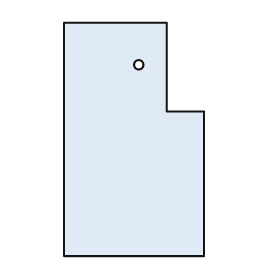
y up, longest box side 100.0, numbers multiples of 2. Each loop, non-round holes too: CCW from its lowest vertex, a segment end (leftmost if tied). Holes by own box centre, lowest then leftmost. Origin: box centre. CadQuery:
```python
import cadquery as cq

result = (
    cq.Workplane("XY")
    .moveTo(-30.0, -50.0)
    .lineTo(30.0, -50.0)
    .lineTo(30.0, 12.0)
    .lineTo(14.0, 12.0)
    .lineTo(14.0, 50.0)
    .lineTo(-30.0, 50.0)
    .close()
    .moveTo(2.0, 32.0)
    .circle(2.0)
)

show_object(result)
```